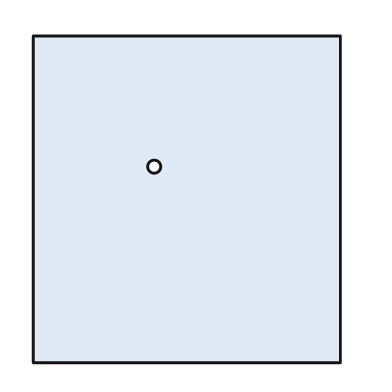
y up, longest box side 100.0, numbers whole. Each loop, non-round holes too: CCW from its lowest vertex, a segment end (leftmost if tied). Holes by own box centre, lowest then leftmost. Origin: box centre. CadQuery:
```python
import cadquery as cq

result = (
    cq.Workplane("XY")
    .moveTo(-47.0, -50.0)
    .lineTo(47.0, -50.0)
    .lineTo(47.0, 50.0)
    .lineTo(-47.0, 50.0)
    .close()
    .moveTo(-10.0, 10.0)
    .circle(2.0)
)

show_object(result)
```